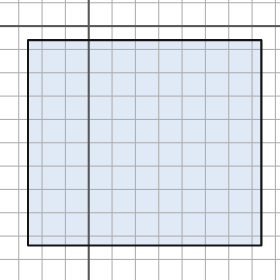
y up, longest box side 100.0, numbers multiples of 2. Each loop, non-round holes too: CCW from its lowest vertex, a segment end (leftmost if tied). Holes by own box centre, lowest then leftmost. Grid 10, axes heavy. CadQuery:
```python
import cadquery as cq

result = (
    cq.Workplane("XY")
    .moveTo(-26.0, -94.0)
    .lineTo(74.0, -94.0)
    .lineTo(74.0, -6.0)
    .lineTo(-26.0, -6.0)
    .close()
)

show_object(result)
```